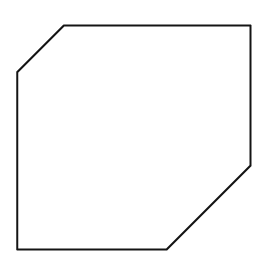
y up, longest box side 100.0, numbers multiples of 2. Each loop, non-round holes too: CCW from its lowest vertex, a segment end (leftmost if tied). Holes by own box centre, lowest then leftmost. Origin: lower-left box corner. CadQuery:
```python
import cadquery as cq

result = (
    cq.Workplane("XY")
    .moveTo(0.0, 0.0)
    .lineTo(64.0, 0.0)
    .lineTo(100.0, 36.0)
    .lineTo(100.0, 96.0)
    .lineTo(20.0, 96.0)
    .lineTo(0.0, 76.0)
    .close()
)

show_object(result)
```